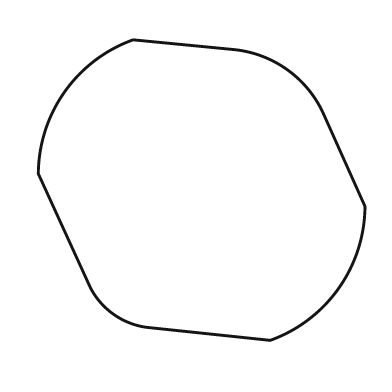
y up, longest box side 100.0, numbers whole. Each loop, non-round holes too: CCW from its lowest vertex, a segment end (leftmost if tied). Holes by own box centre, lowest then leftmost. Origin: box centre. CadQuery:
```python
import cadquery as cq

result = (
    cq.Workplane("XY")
    .moveTo(21.0, -46.0)
    .threePointArc((42.0, -30.0), (50.0, -5.0))
    .lineTo(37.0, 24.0)
    .threePointArc((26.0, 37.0), (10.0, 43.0))
    .lineTo(-21.0, 46.0)
    .threePointArc((-42.0, 30.0), (-50.0, 5.0))
    .lineTo(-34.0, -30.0)
    .threePointArc((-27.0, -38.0), (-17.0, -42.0))
    .close()
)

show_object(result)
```